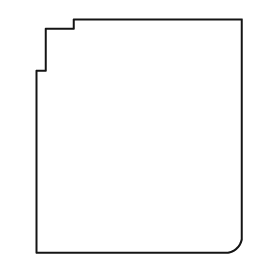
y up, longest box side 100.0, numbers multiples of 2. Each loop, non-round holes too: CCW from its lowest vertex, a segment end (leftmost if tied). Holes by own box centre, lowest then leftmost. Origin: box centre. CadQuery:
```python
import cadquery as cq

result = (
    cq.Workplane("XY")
    .moveTo(-44.0, -50.0)
    .lineTo(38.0, -50.0)
    .threePointArc((42.0, -48.0), (44.0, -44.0))
    .lineTo(44.0, 50.0)
    .lineTo(-28.0, 50.0)
    .lineTo(-28.0, 46.0)
    .lineTo(-40.0, 46.0)
    .lineTo(-40.0, 28.0)
    .lineTo(-44.0, 28.0)
    .close()
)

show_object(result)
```